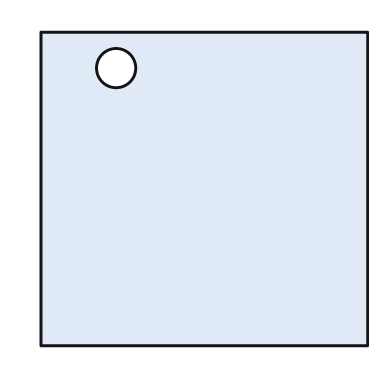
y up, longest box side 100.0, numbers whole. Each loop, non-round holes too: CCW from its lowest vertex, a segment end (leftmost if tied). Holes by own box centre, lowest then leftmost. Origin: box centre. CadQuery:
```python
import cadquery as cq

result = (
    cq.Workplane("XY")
    .moveTo(-50.0, -48.0)
    .lineTo(50.0, -48.0)
    .lineTo(50.0, 48.0)
    .lineTo(-50.0, 48.0)
    .close()
    .moveTo(-27.0, 37.0)
    .circle(6.0)
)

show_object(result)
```